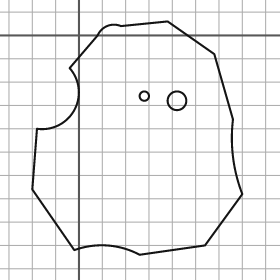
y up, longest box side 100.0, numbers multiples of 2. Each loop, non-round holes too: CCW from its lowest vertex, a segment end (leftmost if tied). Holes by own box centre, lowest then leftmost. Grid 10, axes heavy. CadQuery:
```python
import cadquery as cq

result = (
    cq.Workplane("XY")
    .moveTo(26.0, -94.0)
    .lineTo(54.0, -90.0)
    .lineTo(70.0, -68.0)
    .threePointArc((66.0, -52.0), (66.0, -36.0))
    .lineTo(58.0, -8.0)
    .lineTo(38.0, 6.0)
    .lineTo(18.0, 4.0)
    .threePointArc((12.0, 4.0), (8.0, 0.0))
    .lineTo(-4.0, -14.0)
    .threePointArc((-2.0, -32.0), (-18.0, -40.0))
    .lineTo(-20.0, -66.0)
    .lineTo(-2.0, -92.0)
    .threePointArc((12.0, -90.0), (26.0, -94.0))
    .close()
    .moveTo(42.0, -28.0)
    .circle(4.0)
    .moveTo(28.0, -26.0)
    .circle(2.0)
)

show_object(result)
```